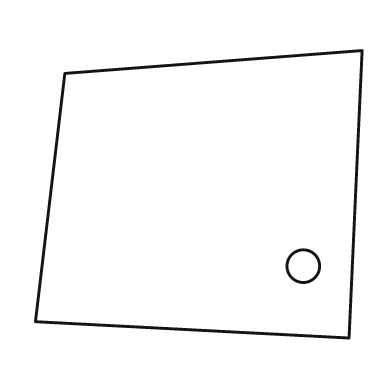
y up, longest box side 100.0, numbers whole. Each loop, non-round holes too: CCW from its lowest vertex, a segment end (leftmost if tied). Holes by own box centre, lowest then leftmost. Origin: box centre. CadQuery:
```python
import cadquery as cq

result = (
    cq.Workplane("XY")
    .moveTo(46.0, -44.0)
    .lineTo(50.0, 44.0)
    .lineTo(-41.0, 37.0)
    .lineTo(-50.0, -39.0)
    .close()
    .moveTo(32.0, -22.0)
    .circle(5.0)
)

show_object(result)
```